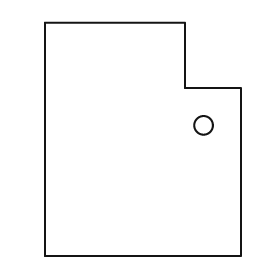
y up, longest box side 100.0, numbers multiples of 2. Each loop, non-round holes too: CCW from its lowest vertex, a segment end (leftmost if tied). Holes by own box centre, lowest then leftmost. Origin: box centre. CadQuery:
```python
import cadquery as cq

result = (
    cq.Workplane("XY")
    .moveTo(-42.0, -50.0)
    .lineTo(42.0, -50.0)
    .lineTo(42.0, 22.0)
    .lineTo(18.0, 22.0)
    .lineTo(18.0, 50.0)
    .lineTo(-42.0, 50.0)
    .close()
    .moveTo(26.0, 6.0)
    .circle(4.0)
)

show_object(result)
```